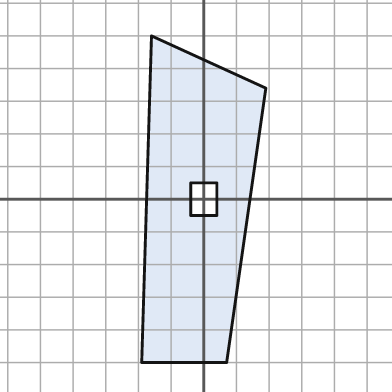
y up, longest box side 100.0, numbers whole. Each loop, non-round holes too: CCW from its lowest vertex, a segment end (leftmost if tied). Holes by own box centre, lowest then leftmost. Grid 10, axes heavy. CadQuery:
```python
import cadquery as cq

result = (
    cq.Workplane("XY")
    .moveTo(-19.0, -50.0)
    .lineTo(7.0, -50.0)
    .lineTo(19.0, 34.0)
    .lineTo(-16.0, 50.0)
    .close()
    .moveTo(-4.0, -5.0)
    .lineTo(4.0, -5.0)
    .lineTo(4.0, 5.0)
    .lineTo(-4.0, 5.0)
    .close()
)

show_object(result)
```